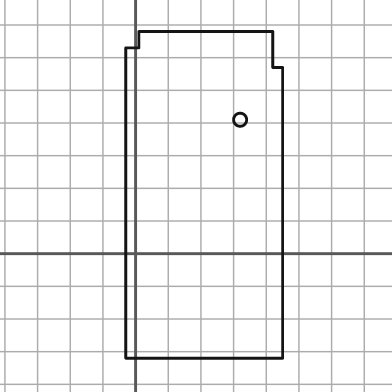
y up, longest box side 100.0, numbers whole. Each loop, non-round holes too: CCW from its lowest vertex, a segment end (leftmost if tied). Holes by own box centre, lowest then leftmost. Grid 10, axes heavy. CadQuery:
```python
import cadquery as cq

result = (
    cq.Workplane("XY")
    .moveTo(-3.0, -32.0)
    .lineTo(45.0, -32.0)
    .lineTo(45.0, 57.0)
    .lineTo(42.0, 57.0)
    .lineTo(42.0, 68.0)
    .lineTo(1.0, 68.0)
    .lineTo(1.0, 63.0)
    .lineTo(-3.0, 63.0)
    .close()
    .moveTo(32.0, 41.0)
    .circle(2.0)
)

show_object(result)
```